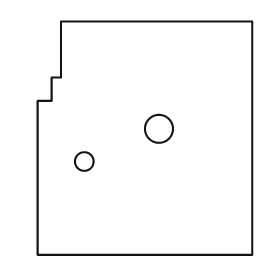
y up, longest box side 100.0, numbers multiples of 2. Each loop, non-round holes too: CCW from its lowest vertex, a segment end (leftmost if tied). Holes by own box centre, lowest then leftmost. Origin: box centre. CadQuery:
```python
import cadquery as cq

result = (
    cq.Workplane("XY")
    .moveTo(-46.0, -50.0)
    .lineTo(46.0, -50.0)
    .lineTo(46.0, 50.0)
    .lineTo(-36.0, 50.0)
    .lineTo(-36.0, 26.0)
    .lineTo(-40.0, 26.0)
    .lineTo(-40.0, 16.0)
    .lineTo(-46.0, 16.0)
    .close()
    .moveTo(-26.0, -10.0)
    .circle(4.0)
    .moveTo(6.0, 4.0)
    .circle(6.0)
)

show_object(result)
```